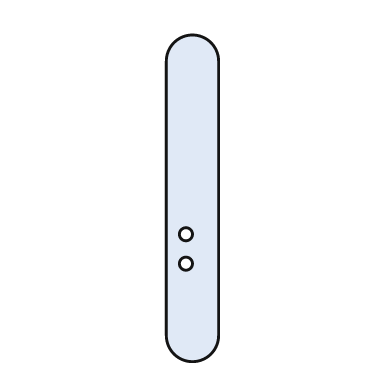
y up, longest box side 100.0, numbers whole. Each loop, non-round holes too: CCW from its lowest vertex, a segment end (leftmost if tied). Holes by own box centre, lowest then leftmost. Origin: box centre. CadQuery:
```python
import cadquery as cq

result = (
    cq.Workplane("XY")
    .moveTo(-8.0, -42.0)
    .threePointArc((0.0, -50.0), (8.0, -42.0))
    .lineTo(8.0, 42.0)
    .threePointArc((0.0, 50.0), (-8.0, 42.0))
    .close()
    .moveTo(-2.0, -20.0)
    .circle(2.0)
    .moveTo(-2.0, -11.0)
    .circle(2.0)
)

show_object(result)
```